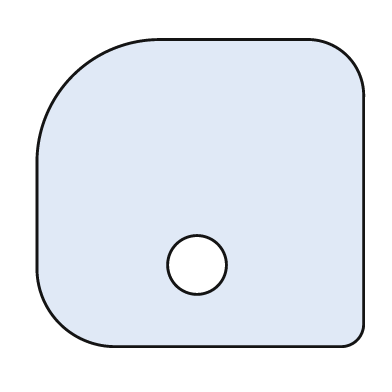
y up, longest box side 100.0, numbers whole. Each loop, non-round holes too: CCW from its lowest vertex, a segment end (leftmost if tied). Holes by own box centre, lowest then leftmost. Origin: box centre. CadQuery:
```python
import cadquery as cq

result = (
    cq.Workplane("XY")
    .moveTo(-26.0, -47.0)
    .lineTo(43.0, -47.0)
    .threePointArc((48.0, -45.0), (50.0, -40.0))
    .lineTo(50.0, 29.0)
    .threePointArc((45.0, 42.0), (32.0, 47.0))
    .lineTo(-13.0, 47.0)
    .threePointArc((-39.0, 36.0), (-50.0, 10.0))
    .lineTo(-50.0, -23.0)
    .threePointArc((-43.0, -40.0), (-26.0, -47.0))
    .close()
    .moveTo(-1.0, -22.0)
    .circle(9.0)
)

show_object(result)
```